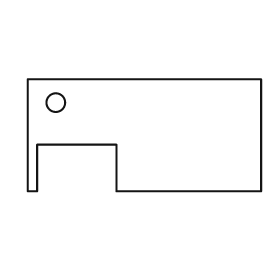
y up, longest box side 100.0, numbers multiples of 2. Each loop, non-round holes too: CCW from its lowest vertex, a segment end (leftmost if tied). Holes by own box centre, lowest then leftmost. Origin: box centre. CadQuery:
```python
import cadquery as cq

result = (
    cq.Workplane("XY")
    .moveTo(-50.0, -24.0)
    .lineTo(-46.0, -24.0)
    .lineTo(-46.0, -4.0)
    .lineTo(-12.0, -4.0)
    .lineTo(-12.0, -24.0)
    .lineTo(50.0, -24.0)
    .lineTo(50.0, 24.0)
    .lineTo(-50.0, 24.0)
    .close()
    .moveTo(-38.0, 14.0)
    .circle(4.0)
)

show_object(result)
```